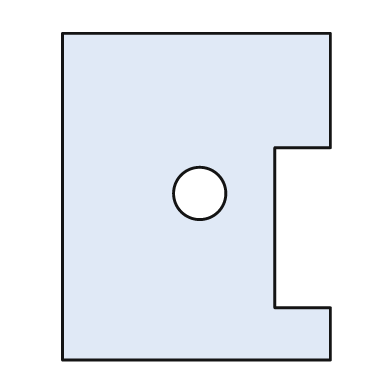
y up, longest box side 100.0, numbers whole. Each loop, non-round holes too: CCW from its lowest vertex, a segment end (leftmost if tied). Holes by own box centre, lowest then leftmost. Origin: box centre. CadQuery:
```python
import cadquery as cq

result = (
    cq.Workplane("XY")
    .moveTo(-41.0, -50.0)
    .lineTo(41.0, -50.0)
    .lineTo(41.0, -34.0)
    .lineTo(24.0, -34.0)
    .lineTo(24.0, 15.0)
    .lineTo(41.0, 15.0)
    .lineTo(41.0, 50.0)
    .lineTo(-41.0, 50.0)
    .close()
    .moveTo(1.0, 1.0)
    .circle(8.0)
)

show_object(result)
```